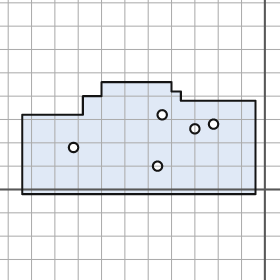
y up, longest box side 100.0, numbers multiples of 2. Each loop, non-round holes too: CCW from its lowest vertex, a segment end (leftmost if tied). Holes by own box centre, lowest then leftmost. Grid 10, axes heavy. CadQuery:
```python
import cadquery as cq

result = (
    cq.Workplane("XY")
    .moveTo(-104.0, -2.0)
    .lineTo(-4.0, -2.0)
    .lineTo(-4.0, 38.0)
    .lineTo(-36.0, 38.0)
    .lineTo(-36.0, 42.0)
    .lineTo(-40.0, 42.0)
    .lineTo(-40.0, 46.0)
    .lineTo(-70.0, 46.0)
    .lineTo(-70.0, 40.0)
    .lineTo(-78.0, 40.0)
    .lineTo(-78.0, 32.0)
    .lineTo(-104.0, 32.0)
    .close()
    .moveTo(-46.0, 10.0)
    .circle(2.0)
    .moveTo(-82.0, 18.0)
    .circle(2.0)
    .moveTo(-30.0, 26.0)
    .circle(2.0)
    .moveTo(-22.0, 28.0)
    .circle(2.0)
    .moveTo(-44.0, 32.0)
    .circle(2.0)
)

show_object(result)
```